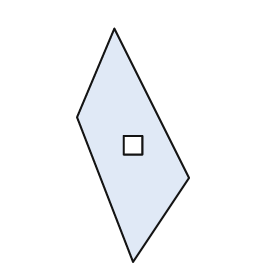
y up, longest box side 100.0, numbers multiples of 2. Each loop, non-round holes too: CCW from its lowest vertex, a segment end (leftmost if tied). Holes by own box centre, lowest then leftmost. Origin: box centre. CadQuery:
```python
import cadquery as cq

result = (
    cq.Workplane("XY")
    .moveTo(0.0, -50.0)
    .lineTo(24.0, -14.0)
    .lineTo(-8.0, 50.0)
    .lineTo(-24.0, 12.0)
    .close()
    .moveTo(-4.0, -4.0)
    .lineTo(4.0, -4.0)
    .lineTo(4.0, 4.0)
    .lineTo(-4.0, 4.0)
    .close()
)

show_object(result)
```